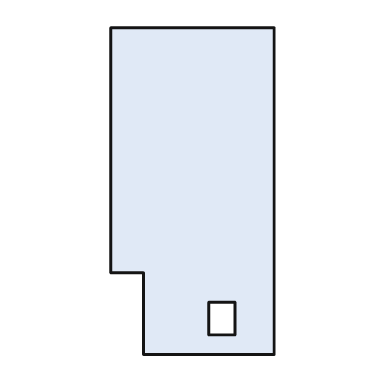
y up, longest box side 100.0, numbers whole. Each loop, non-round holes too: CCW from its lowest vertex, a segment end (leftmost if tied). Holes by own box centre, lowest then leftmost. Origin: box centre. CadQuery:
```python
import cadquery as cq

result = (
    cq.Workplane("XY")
    .moveTo(-15.0, -50.0)
    .lineTo(25.0, -50.0)
    .lineTo(25.0, 50.0)
    .lineTo(-25.0, 50.0)
    .lineTo(-25.0, -25.0)
    .lineTo(-15.0, -25.0)
    .close()
    .moveTo(5.0, -44.0)
    .lineTo(13.0, -44.0)
    .lineTo(13.0, -34.0)
    .lineTo(5.0, -34.0)
    .close()
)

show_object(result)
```